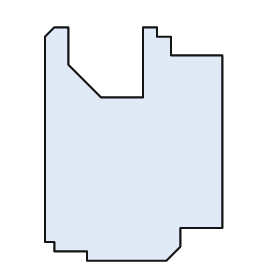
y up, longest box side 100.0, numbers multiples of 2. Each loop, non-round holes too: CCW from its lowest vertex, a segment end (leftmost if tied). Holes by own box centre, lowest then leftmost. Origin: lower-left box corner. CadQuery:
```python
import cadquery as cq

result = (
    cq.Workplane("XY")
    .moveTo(18.0, 0.0)
    .lineTo(52.0, 0.0)
    .lineTo(58.0, 6.0)
    .lineTo(58.0, 14.0)
    .lineTo(76.0, 14.0)
    .lineTo(76.0, 88.0)
    .lineTo(54.0, 88.0)
    .lineTo(54.0, 96.0)
    .lineTo(48.0, 96.0)
    .lineTo(48.0, 100.0)
    .lineTo(42.0, 100.0)
    .lineTo(42.0, 70.0)
    .lineTo(24.0, 70.0)
    .lineTo(10.0, 84.0)
    .lineTo(10.0, 100.0)
    .lineTo(4.0, 100.0)
    .lineTo(0.0, 96.0)
    .lineTo(0.0, 8.0)
    .lineTo(4.0, 8.0)
    .lineTo(4.0, 4.0)
    .lineTo(18.0, 4.0)
    .close()
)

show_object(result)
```